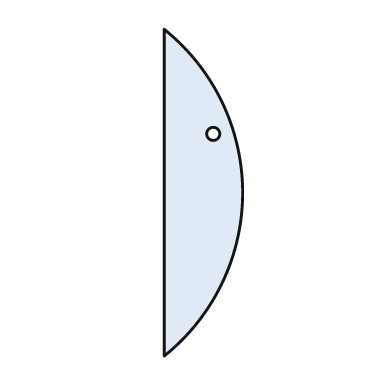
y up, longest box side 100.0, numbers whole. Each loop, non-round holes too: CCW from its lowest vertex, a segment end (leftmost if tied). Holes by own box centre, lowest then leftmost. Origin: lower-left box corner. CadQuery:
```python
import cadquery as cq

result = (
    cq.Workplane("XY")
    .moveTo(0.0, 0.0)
    .threePointArc((24.0, 50.0), (0.0, 100.0))
    .close()
    .moveTo(15.0, 68.0)
    .circle(2.0)
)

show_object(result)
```